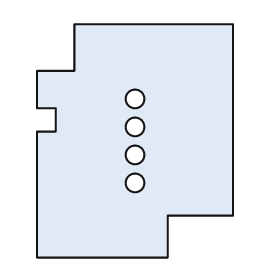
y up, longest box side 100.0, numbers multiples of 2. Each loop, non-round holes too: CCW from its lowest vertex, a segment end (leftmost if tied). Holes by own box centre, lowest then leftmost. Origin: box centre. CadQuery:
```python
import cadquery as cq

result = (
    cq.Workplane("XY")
    .moveTo(-42.0, -50.0)
    .lineTo(14.0, -50.0)
    .lineTo(14.0, -32.0)
    .lineTo(42.0, -32.0)
    .lineTo(42.0, 50.0)
    .lineTo(-26.0, 50.0)
    .lineTo(-26.0, 30.0)
    .lineTo(-42.0, 30.0)
    .lineTo(-42.0, 14.0)
    .lineTo(-34.0, 14.0)
    .lineTo(-34.0, 4.0)
    .lineTo(-42.0, 4.0)
    .close()
    .moveTo(0.0, -18.0)
    .circle(4.0)
    .moveTo(0.0, -6.0)
    .circle(4.0)
    .moveTo(0.0, 6.0)
    .circle(4.0)
    .moveTo(0.0, 18.0)
    .circle(4.0)
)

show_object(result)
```